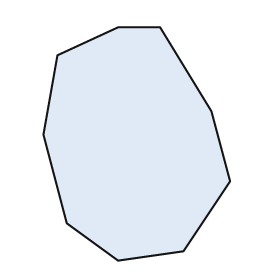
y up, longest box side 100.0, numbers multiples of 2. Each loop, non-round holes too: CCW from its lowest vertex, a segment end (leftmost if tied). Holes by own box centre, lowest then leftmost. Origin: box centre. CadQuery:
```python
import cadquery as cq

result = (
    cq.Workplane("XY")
    .moveTo(-8.0, -50.0)
    .lineTo(20.0, -46.0)
    .lineTo(40.0, -16.0)
    .lineTo(32.0, 14.0)
    .lineTo(10.0, 50.0)
    .lineTo(-8.0, 50.0)
    .lineTo(-34.0, 38.0)
    .lineTo(-40.0, 4.0)
    .lineTo(-30.0, -34.0)
    .close()
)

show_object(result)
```